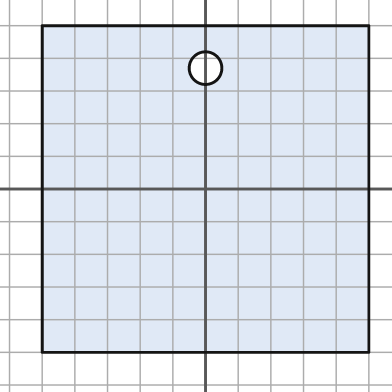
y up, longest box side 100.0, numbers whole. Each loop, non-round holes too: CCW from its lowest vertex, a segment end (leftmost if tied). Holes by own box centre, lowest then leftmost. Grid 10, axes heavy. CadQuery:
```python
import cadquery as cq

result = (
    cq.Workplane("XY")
    .moveTo(-50.0, -50.0)
    .lineTo(50.0, -50.0)
    .lineTo(50.0, 50.0)
    .lineTo(-50.0, 50.0)
    .close()
    .moveTo(0.0, 37.0)
    .circle(5.0)
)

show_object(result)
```